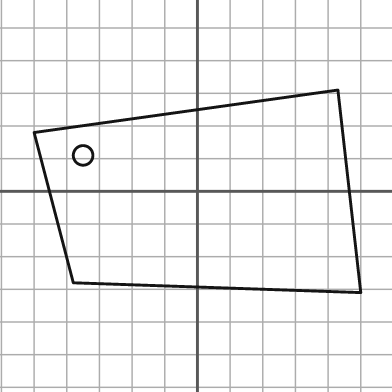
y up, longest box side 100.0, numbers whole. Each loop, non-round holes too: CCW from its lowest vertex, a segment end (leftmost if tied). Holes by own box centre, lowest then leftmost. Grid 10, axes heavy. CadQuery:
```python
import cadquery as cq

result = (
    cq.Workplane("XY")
    .moveTo(50.0, -31.0)
    .lineTo(43.0, 31.0)
    .lineTo(-50.0, 18.0)
    .lineTo(-38.0, -28.0)
    .close()
    .moveTo(-35.0, 11.0)
    .circle(3.0)
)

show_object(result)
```